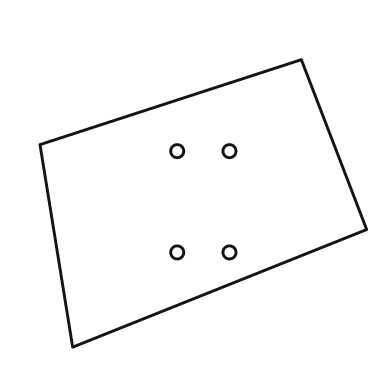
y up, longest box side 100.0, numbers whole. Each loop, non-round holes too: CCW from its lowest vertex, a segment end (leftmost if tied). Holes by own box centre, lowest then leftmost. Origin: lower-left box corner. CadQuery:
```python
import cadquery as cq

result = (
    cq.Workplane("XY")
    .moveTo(10.0, 0.0)
    .lineTo(100.0, 36.0)
    .lineTo(80.0, 88.0)
    .lineTo(0.0, 62.0)
    .close()
    .moveTo(42.0, 29.0)
    .circle(2.0)
    .moveTo(58.0, 29.0)
    .circle(2.0)
    .moveTo(42.0, 60.0)
    .circle(2.0)
    .moveTo(58.0, 60.0)
    .circle(2.0)
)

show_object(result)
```